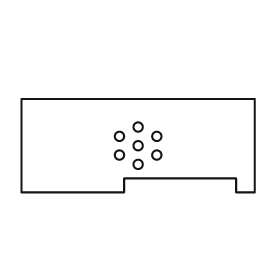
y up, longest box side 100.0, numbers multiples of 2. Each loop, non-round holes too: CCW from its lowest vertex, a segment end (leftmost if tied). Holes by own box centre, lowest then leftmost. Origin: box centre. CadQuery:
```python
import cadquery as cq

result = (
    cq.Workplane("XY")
    .moveTo(-50.0, -20.0)
    .lineTo(-6.0, -20.0)
    .lineTo(-6.0, -14.0)
    .lineTo(42.0, -14.0)
    .lineTo(42.0, -20.0)
    .lineTo(50.0, -20.0)
    .lineTo(50.0, 20.0)
    .lineTo(-50.0, 20.0)
    .close()
    .moveTo(0.0, -8.0)
    .circle(2.0)
    .moveTo(-8.0, -4.0)
    .circle(2.0)
    .moveTo(8.0, -4.0)
    .circle(2.0)
    .moveTo(0.0, 0.0)
    .circle(2.0)
    .moveTo(-8.0, 4.0)
    .circle(2.0)
    .moveTo(8.0, 4.0)
    .circle(2.0)
    .moveTo(0.0, 8.0)
    .circle(2.0)
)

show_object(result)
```